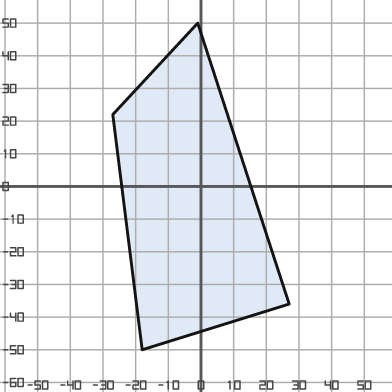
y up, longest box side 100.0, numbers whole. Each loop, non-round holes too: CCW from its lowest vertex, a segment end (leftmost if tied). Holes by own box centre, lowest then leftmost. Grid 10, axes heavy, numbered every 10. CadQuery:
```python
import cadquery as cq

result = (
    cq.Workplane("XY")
    .moveTo(-18.0, -50.0)
    .lineTo(27.0, -36.0)
    .lineTo(-1.0, 50.0)
    .lineTo(-27.0, 22.0)
    .close()
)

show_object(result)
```